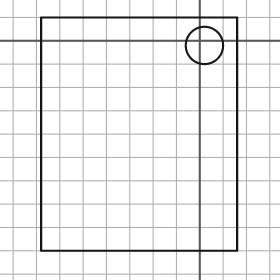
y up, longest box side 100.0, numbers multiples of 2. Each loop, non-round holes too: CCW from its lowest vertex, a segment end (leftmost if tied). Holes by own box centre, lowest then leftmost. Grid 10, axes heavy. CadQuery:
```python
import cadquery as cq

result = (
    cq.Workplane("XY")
    .moveTo(-68.0, -90.0)
    .lineTo(16.0, -90.0)
    .lineTo(16.0, 10.0)
    .lineTo(-68.0, 10.0)
    .close()
    .moveTo(2.0, -2.0)
    .circle(8.0)
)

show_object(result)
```